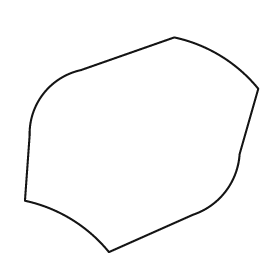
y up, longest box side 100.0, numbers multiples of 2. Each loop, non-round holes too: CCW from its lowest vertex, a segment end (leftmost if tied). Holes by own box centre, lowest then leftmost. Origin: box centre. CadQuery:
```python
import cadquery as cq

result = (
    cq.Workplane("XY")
    .moveTo(-14.0, -46.0)
    .lineTo(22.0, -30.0)
    .threePointArc((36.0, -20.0), (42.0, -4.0))
    .lineTo(50.0, 24.0)
    .threePointArc((34.0, 38.0), (14.0, 46.0))
    .lineTo(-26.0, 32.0)
    .threePointArc((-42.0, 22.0), (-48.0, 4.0))
    .lineTo(-50.0, -24.0)
    .threePointArc((-30.0, -32.0), (-14.0, -46.0))
    .close()
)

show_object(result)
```